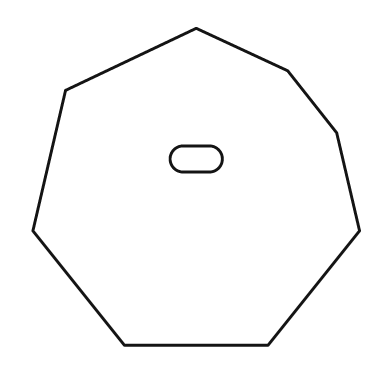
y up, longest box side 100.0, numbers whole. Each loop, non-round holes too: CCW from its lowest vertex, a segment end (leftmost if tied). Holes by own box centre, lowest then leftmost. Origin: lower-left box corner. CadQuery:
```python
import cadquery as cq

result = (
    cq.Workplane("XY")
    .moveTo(28.0, 0.0)
    .lineTo(72.0, 0.0)
    .lineTo(100.0, 35.0)
    .lineTo(93.0, 65.0)
    .lineTo(78.0, 84.0)
    .lineTo(50.0, 97.0)
    .lineTo(10.0, 78.0)
    .lineTo(0.0, 35.0)
    .close()
    .moveTo(46.0, 53.0)
    .lineTo(54.0, 53.0)
    .threePointArc((58.0, 57.0), (54.0, 61.0))
    .lineTo(46.0, 61.0)
    .threePointArc((42.0, 57.0), (46.0, 53.0))
    .close()
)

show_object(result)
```